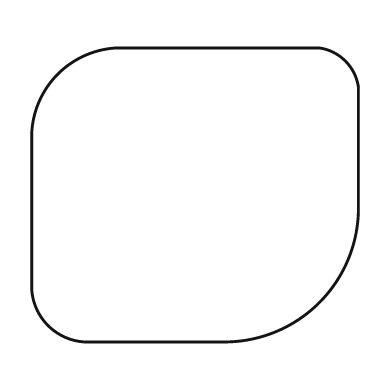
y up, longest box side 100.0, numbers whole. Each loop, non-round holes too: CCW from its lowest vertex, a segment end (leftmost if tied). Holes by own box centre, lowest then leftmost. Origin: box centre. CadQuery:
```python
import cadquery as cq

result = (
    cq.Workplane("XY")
    .moveTo(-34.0, -45.0)
    .lineTo(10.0, -45.0)
    .threePointArc((38.0, -33.0), (50.0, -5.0))
    .lineTo(50.0, 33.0)
    .threePointArc((46.0, 41.0), (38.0, 45.0))
    .lineTo(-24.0, 45.0)
    .threePointArc((-42.0, 37.0), (-50.0, 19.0))
    .lineTo(-50.0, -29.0)
    .threePointArc((-45.0, -40.0), (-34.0, -45.0))
    .close()
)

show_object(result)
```